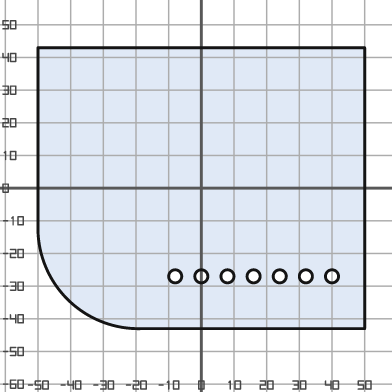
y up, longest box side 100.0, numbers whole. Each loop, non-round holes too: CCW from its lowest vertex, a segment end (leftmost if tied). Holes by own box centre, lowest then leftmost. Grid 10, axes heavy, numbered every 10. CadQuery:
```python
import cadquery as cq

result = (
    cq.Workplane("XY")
    .moveTo(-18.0, -43.0)
    .lineTo(50.0, -43.0)
    .lineTo(50.0, 43.0)
    .lineTo(-50.0, 43.0)
    .lineTo(-50.0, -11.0)
    .threePointArc((-41.0, -34.0), (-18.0, -43.0))
    .close()
    .moveTo(-8.0, -27.0)
    .circle(2.0)
    .moveTo(0.0, -27.0)
    .circle(2.0)
    .moveTo(8.0, -27.0)
    .circle(2.0)
    .moveTo(16.0, -27.0)
    .circle(2.0)
    .moveTo(24.0, -27.0)
    .circle(2.0)
    .moveTo(32.0, -27.0)
    .circle(2.0)
    .moveTo(40.0, -27.0)
    .circle(2.0)
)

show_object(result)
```